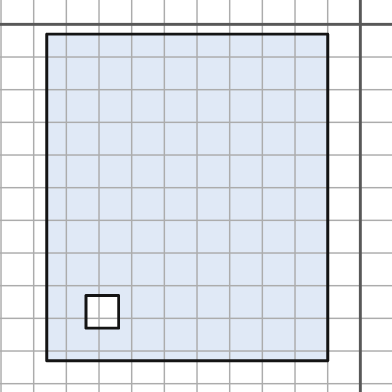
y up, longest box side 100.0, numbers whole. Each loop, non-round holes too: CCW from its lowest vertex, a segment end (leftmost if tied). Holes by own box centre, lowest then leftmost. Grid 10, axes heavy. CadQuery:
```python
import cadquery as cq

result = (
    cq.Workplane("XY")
    .moveTo(-96.0, -103.0)
    .lineTo(-10.0, -103.0)
    .lineTo(-10.0, -3.0)
    .lineTo(-96.0, -3.0)
    .close()
    .moveTo(-84.0, -93.0)
    .lineTo(-74.0, -93.0)
    .lineTo(-74.0, -83.0)
    .lineTo(-84.0, -83.0)
    .close()
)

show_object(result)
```